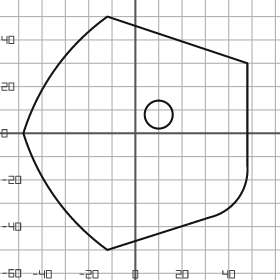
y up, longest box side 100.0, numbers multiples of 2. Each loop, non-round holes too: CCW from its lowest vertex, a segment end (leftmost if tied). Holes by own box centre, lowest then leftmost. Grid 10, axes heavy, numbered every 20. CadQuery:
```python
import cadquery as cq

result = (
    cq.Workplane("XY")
    .moveTo(-12.0, -50.0)
    .lineTo(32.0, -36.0)
    .threePointArc((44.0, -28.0), (48.0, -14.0))
    .lineTo(48.0, 30.0)
    .lineTo(-12.0, 50.0)
    .threePointArc((-34.0, 28.0), (-48.0, 0.0))
    .threePointArc((-34.0, -28.0), (-12.0, -50.0))
    .close()
    .moveTo(10.0, 8.0)
    .circle(6.0)
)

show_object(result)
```